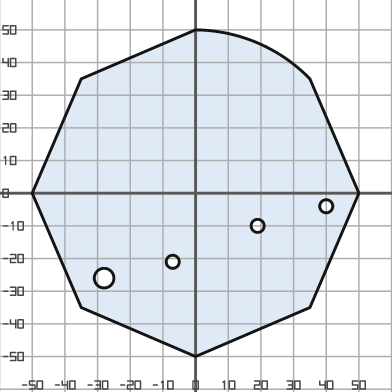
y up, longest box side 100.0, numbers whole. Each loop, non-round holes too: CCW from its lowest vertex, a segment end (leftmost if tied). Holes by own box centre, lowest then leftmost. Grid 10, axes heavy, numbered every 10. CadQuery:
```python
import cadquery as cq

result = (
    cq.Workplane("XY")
    .moveTo(0.0, -50.0)
    .lineTo(35.0, -35.0)
    .lineTo(50.0, 0.0)
    .lineTo(35.0, 35.0)
    .threePointArc((19.0, 46.0), (0.0, 50.0))
    .lineTo(-35.0, 35.0)
    .lineTo(-50.0, 0.0)
    .lineTo(-35.0, -35.0)
    .close()
    .moveTo(-28.0, -26.0)
    .circle(3.0)
    .moveTo(-7.0, -21.0)
    .circle(2.0)
    .moveTo(19.0, -10.0)
    .circle(2.0)
    .moveTo(40.0, -4.0)
    .circle(2.0)
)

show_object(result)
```